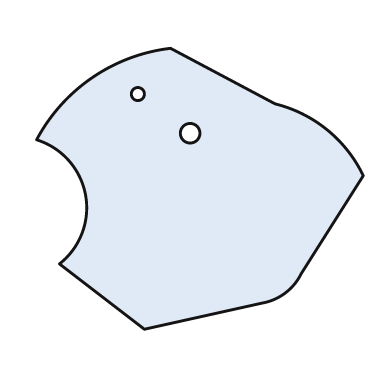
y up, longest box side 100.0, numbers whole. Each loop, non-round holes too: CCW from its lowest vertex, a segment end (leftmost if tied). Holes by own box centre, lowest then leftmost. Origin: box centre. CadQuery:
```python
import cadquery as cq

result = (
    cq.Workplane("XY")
    .moveTo(-17.0, -43.0)
    .lineTo(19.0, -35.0)
    .threePointArc((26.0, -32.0), (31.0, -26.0))
    .lineTo(50.0, 4.0)
    .threePointArc((39.0, 18.0), (23.0, 26.0))
    .lineTo(-9.0, 43.0)
    .threePointArc((-33.0, 34.0), (-50.0, 15.0))
    .threePointArc((-35.0, -2.0), (-43.0, -23.0))
    .close()
    .moveTo(-3.0, 17.0)
    .circle(3.0)
    .moveTo(-19.0, 29.0)
    .circle(2.0)
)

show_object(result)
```